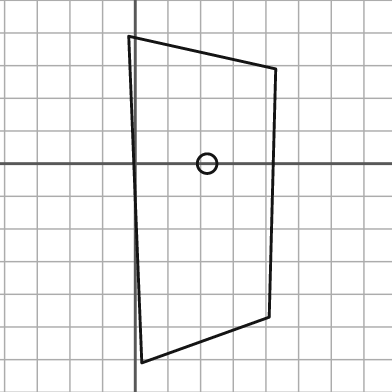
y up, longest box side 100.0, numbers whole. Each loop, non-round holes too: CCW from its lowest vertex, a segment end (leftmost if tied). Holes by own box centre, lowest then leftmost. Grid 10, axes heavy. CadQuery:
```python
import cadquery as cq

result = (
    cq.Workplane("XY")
    .moveTo(2.0, -61.0)
    .lineTo(41.0, -47.0)
    .lineTo(43.0, 29.0)
    .lineTo(-2.0, 39.0)
    .close()
    .moveTo(22.0, 0.0)
    .circle(3.0)
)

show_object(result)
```